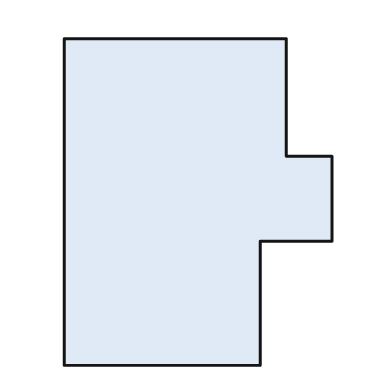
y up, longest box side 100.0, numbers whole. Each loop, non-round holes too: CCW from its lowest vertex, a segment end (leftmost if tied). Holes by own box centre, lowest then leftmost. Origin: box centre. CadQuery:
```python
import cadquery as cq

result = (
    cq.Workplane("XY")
    .moveTo(-41.0, -50.0)
    .lineTo(19.0, -50.0)
    .lineTo(19.0, -12.0)
    .lineTo(41.0, -12.0)
    .lineTo(41.0, 14.0)
    .lineTo(27.0, 14.0)
    .lineTo(27.0, 50.0)
    .lineTo(-41.0, 50.0)
    .close()
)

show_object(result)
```